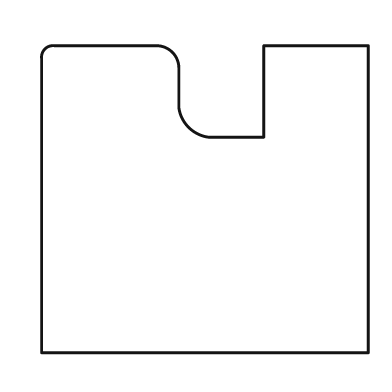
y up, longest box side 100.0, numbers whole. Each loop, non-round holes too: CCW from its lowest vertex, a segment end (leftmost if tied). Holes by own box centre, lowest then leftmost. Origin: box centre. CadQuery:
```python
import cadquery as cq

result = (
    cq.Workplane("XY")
    .moveTo(-50.0, -47.0)
    .lineTo(50.0, -47.0)
    .lineTo(50.0, 47.0)
    .lineTo(18.0, 47.0)
    .lineTo(18.0, 19.0)
    .lineTo(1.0, 19.0)
    .threePointArc((-5.0, 22.0), (-8.0, 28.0))
    .lineTo(-8.0, 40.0)
    .threePointArc((-10.0, 45.0), (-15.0, 47.0))
    .lineTo(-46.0, 47.0)
    .threePointArc((-49.0, 46.0), (-50.0, 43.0))
    .close()
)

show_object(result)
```